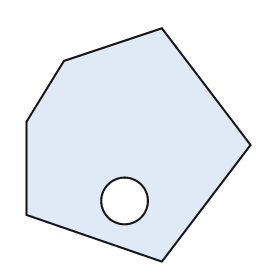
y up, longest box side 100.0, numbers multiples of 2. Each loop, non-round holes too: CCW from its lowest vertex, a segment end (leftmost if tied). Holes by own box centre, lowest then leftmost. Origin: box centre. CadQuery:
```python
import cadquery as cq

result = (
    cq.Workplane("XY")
    .moveTo(10.0, -50.0)
    .lineTo(48.0, 0.0)
    .lineTo(10.0, 50.0)
    .lineTo(-32.0, 36.0)
    .lineTo(-48.0, 10.0)
    .lineTo(-48.0, -30.0)
    .close()
    .moveTo(-6.0, -24.0)
    .circle(10.0)
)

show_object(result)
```